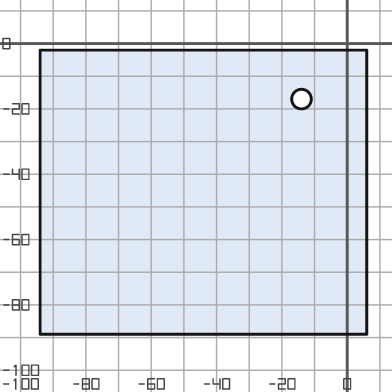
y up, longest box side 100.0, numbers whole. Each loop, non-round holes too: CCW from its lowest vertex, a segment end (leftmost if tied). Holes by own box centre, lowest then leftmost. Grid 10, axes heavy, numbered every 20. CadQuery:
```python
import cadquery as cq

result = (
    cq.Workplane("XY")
    .moveTo(-94.0, -89.0)
    .lineTo(6.0, -89.0)
    .lineTo(6.0, -2.0)
    .lineTo(-94.0, -2.0)
    .close()
    .moveTo(-14.0, -17.0)
    .circle(3.0)
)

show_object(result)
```